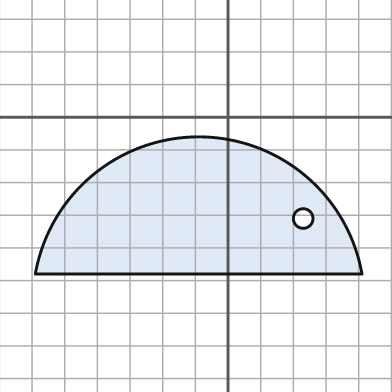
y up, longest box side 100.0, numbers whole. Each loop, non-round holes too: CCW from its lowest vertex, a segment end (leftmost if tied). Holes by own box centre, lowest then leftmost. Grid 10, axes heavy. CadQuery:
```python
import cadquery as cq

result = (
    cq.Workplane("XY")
    .moveTo(-59.0, -48.0)
    .lineTo(41.0, -48.0)
    .threePointArc((-9.0, -6.0), (-59.0, -48.0))
    .close()
    .moveTo(23.0, -31.0)
    .circle(3.0)
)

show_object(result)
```